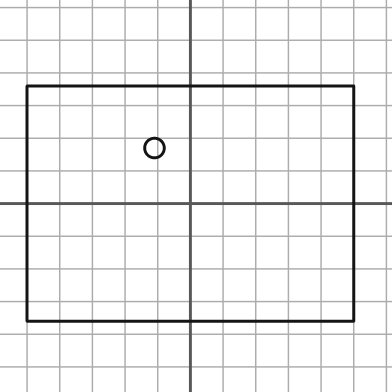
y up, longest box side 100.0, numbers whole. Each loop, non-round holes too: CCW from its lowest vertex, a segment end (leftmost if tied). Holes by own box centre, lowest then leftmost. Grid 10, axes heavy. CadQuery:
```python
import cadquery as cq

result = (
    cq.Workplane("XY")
    .moveTo(-50.0, -36.0)
    .lineTo(50.0, -36.0)
    .lineTo(50.0, 36.0)
    .lineTo(-50.0, 36.0)
    .close()
    .moveTo(-11.0, 17.0)
    .circle(3.0)
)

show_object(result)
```